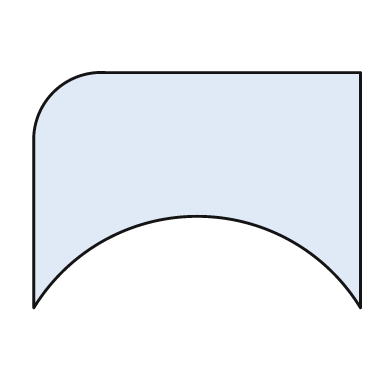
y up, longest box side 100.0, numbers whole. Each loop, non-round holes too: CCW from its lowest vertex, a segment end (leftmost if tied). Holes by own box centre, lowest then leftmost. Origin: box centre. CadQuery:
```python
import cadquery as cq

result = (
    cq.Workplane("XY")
    .moveTo(-50.0, -36.0)
    .threePointArc((0.0, -8.0), (50.0, -36.0))
    .lineTo(50.0, 36.0)
    .lineTo(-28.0, 36.0)
    .threePointArc((-44.0, 30.0), (-50.0, 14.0))
    .close()
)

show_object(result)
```